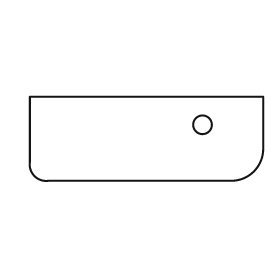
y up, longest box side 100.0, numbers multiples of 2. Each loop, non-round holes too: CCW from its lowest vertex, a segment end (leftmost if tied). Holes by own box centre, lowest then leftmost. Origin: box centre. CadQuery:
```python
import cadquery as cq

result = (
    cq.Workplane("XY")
    .moveTo(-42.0, -18.0)
    .lineTo(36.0, -18.0)
    .threePointArc((46.0, -14.0), (50.0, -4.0))
    .lineTo(50.0, 18.0)
    .lineTo(-50.0, 18.0)
    .lineTo(-50.0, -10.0)
    .threePointArc((-48.0, -16.0), (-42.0, -18.0))
    .close()
    .moveTo(24.0, 6.0)
    .circle(4.0)
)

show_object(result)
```